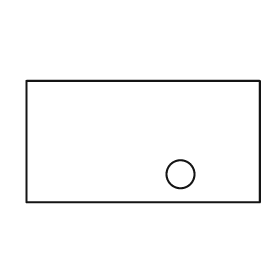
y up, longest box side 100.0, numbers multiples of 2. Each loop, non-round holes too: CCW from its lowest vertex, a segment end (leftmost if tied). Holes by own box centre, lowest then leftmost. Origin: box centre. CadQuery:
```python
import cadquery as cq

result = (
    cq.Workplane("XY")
    .moveTo(-50.0, -26.0)
    .lineTo(50.0, -26.0)
    .lineTo(50.0, 26.0)
    .lineTo(-50.0, 26.0)
    .close()
    .moveTo(16.0, -14.0)
    .circle(6.0)
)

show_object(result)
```